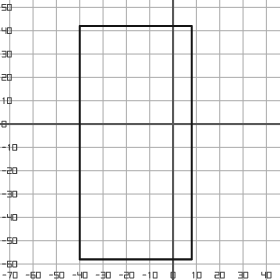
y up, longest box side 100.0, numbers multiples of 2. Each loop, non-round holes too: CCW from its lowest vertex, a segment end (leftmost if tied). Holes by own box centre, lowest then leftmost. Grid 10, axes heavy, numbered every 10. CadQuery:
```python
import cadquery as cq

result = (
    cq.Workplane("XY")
    .moveTo(-40.0, -58.0)
    .lineTo(8.0, -58.0)
    .lineTo(8.0, 42.0)
    .lineTo(-40.0, 42.0)
    .close()
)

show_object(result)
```